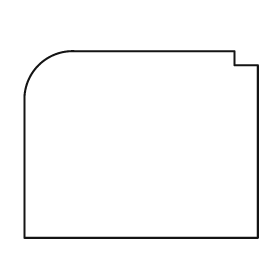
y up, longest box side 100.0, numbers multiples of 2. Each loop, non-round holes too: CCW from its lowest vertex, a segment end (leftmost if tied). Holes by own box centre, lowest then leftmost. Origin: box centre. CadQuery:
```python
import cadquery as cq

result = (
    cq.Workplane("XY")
    .moveTo(-50.0, -40.0)
    .lineTo(50.0, -40.0)
    .lineTo(50.0, 34.0)
    .lineTo(40.0, 34.0)
    .lineTo(40.0, 40.0)
    .lineTo(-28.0, 40.0)
    .threePointArc((-44.0, 34.0), (-50.0, 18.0))
    .close()
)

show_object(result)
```